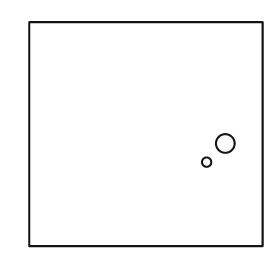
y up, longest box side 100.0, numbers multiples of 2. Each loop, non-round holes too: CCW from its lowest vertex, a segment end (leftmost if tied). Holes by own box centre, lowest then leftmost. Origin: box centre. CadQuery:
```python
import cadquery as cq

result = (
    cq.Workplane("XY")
    .moveTo(-50.0, -48.0)
    .lineTo(50.0, -48.0)
    .lineTo(50.0, 48.0)
    .lineTo(-50.0, 48.0)
    .close()
    .moveTo(26.0, -12.0)
    .circle(2.0)
    .moveTo(34.0, -4.0)
    .circle(4.0)
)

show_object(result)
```